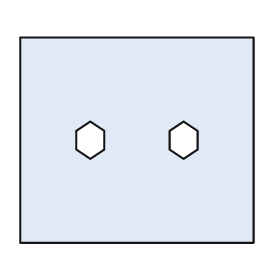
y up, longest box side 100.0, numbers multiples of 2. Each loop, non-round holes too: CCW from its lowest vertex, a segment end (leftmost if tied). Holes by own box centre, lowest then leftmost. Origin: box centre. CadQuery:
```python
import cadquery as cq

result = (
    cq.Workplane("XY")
    .moveTo(-50.0, -44.0)
    .lineTo(50.0, -44.0)
    .lineTo(50.0, 44.0)
    .lineTo(-50.0, 44.0)
    .close()
    .moveTo(-20.0, -8.0)
    .lineTo(-14.0, -4.0)
    .lineTo(-14.0, 4.0)
    .lineTo(-20.0, 8.0)
    .lineTo(-26.0, 4.0)
    .lineTo(-26.0, -4.0)
    .close()
    .moveTo(20.0, -8.0)
    .lineTo(26.0, -4.0)
    .lineTo(26.0, 4.0)
    .lineTo(20.0, 8.0)
    .lineTo(14.0, 4.0)
    .lineTo(14.0, -4.0)
    .close()
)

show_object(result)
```